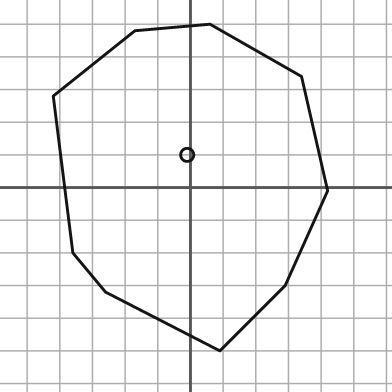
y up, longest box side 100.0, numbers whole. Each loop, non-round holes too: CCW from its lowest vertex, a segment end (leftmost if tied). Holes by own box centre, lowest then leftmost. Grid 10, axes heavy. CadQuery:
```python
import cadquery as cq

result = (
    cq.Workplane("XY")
    .moveTo(9.0, -50.0)
    .lineTo(29.0, -30.0)
    .lineTo(42.0, -1.0)
    .lineTo(34.0, 34.0)
    .lineTo(6.0, 50.0)
    .lineTo(-17.0, 48.0)
    .lineTo(-42.0, 28.0)
    .lineTo(-36.0, -20.0)
    .lineTo(-26.0, -32.0)
    .close()
    .moveTo(-1.0, 10.0)
    .circle(2.0)
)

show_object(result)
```